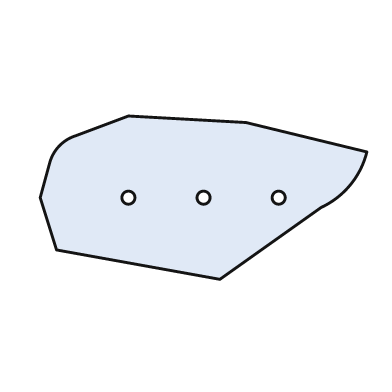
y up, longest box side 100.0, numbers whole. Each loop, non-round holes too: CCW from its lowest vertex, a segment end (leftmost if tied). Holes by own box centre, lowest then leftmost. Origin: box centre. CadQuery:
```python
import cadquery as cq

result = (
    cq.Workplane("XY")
    .moveTo(5.0, -25.0)
    .lineTo(36.0, -3.0)
    .threePointArc((45.0, 4.0), (50.0, 14.0))
    .lineTo(13.0, 23.0)
    .lineTo(-23.0, 25.0)
    .lineTo(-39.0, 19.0)
    .threePointArc((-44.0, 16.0), (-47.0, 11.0))
    .lineTo(-50.0, 0.0)
    .lineTo(-45.0, -16.0)
    .close()
    .moveTo(-23.0, 0.0)
    .circle(2.0)
    .moveTo(0.0, 0.0)
    .circle(2.0)
    .moveTo(23.0, 0.0)
    .circle(2.0)
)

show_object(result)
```